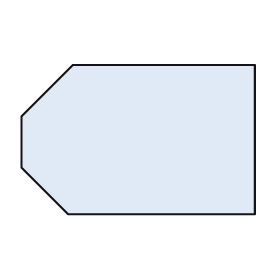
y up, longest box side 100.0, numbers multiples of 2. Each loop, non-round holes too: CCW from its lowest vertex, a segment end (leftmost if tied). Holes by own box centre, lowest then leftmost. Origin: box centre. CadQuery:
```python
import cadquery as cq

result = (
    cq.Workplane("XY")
    .moveTo(-30.0, -32.0)
    .lineTo(50.0, -32.0)
    .lineTo(50.0, 32.0)
    .lineTo(-28.0, 32.0)
    .lineTo(-50.0, 10.0)
    .lineTo(-50.0, -12.0)
    .close()
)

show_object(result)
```